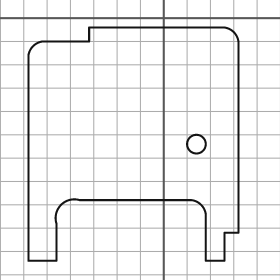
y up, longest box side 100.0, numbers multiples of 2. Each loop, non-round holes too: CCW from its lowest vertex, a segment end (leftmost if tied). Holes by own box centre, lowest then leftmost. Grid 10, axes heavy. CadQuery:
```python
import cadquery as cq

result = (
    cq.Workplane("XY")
    .moveTo(-58.0, -104.0)
    .lineTo(-46.0, -104.0)
    .lineTo(-46.0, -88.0)
    .threePointArc((-44.0, -80.0), (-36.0, -78.0))
    .lineTo(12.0, -78.0)
    .threePointArc((16.0, -80.0), (18.0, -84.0))
    .lineTo(18.0, -104.0)
    .lineTo(26.0, -104.0)
    .lineTo(26.0, -92.0)
    .lineTo(32.0, -92.0)
    .lineTo(32.0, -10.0)
    .threePointArc((30.0, -6.0), (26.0, -4.0))
    .lineTo(-32.0, -4.0)
    .lineTo(-32.0, -10.0)
    .lineTo(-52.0, -10.0)
    .threePointArc((-56.0, -12.0), (-58.0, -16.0))
    .close()
    .moveTo(14.0, -54.0)
    .circle(4.0)
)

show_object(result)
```